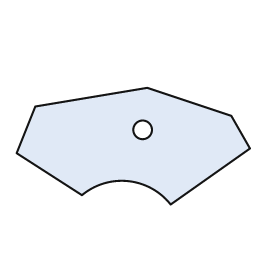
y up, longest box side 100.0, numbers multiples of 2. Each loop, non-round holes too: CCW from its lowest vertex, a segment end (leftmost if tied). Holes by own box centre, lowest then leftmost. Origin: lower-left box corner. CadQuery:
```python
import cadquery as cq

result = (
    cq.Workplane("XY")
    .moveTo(66.0, 0.0)
    .lineTo(100.0, 24.0)
    .lineTo(92.0, 38.0)
    .lineTo(56.0, 50.0)
    .lineTo(8.0, 42.0)
    .lineTo(0.0, 22.0)
    .lineTo(28.0, 4.0)
    .threePointArc((48.0, 10.0), (66.0, 0.0))
    .close()
    .moveTo(54.0, 32.0)
    .circle(4.0)
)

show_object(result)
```